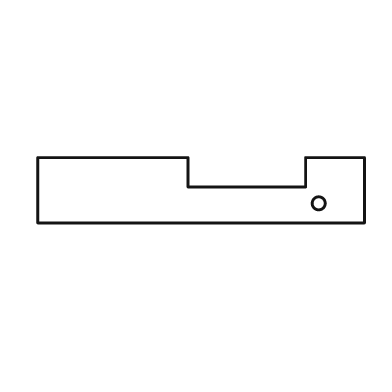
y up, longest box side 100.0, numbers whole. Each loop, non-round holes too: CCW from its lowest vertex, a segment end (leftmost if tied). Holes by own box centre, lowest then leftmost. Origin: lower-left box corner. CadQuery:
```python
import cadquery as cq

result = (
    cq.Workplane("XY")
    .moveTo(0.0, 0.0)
    .lineTo(100.0, 0.0)
    .lineTo(100.0, 20.0)
    .lineTo(82.0, 20.0)
    .lineTo(82.0, 11.0)
    .lineTo(46.0, 11.0)
    .lineTo(46.0, 20.0)
    .lineTo(0.0, 20.0)
    .close()
    .moveTo(86.0, 6.0)
    .circle(2.0)
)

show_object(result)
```